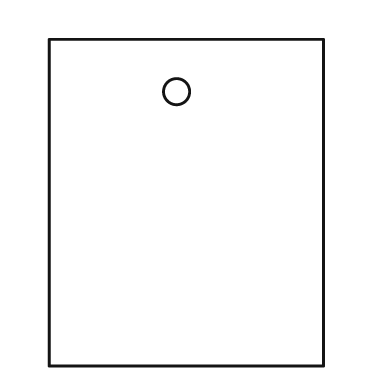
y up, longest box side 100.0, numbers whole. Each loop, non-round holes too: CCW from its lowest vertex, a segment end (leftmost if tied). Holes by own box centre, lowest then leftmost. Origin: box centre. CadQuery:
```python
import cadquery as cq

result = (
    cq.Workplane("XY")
    .moveTo(-42.0, -50.0)
    .lineTo(42.0, -50.0)
    .lineTo(42.0, 50.0)
    .lineTo(-42.0, 50.0)
    .close()
    .moveTo(-3.0, 34.0)
    .circle(4.0)
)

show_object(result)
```